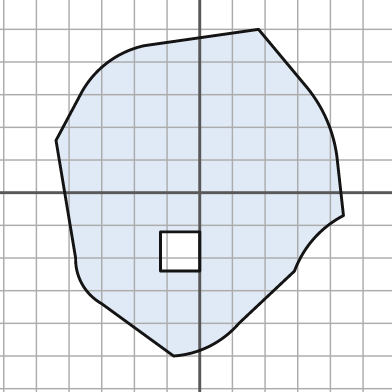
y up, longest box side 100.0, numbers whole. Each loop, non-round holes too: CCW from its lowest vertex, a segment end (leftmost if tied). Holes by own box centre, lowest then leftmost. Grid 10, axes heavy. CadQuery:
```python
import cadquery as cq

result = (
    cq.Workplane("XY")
    .moveTo(-8.0, -50.0)
    .threePointArc((3.0, -47.0), (12.0, -40.0))
    .lineTo(29.0, -24.0)
    .threePointArc((35.0, -14.0), (44.0, -7.0))
    .lineTo(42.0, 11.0)
    .threePointArc((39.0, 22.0), (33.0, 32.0))
    .lineTo(18.0, 50.0)
    .lineTo(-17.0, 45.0)
    .threePointArc((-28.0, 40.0), (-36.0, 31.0))
    .lineTo(-44.0, 16.0)
    .lineTo(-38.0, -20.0)
    .threePointArc((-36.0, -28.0), (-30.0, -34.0))
    .close()
    .moveTo(-12.0, -24.0)
    .lineTo(0.0, -24.0)
    .lineTo(0.0, -12.0)
    .lineTo(-12.0, -12.0)
    .close()
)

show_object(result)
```